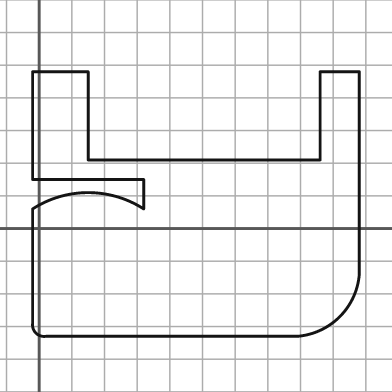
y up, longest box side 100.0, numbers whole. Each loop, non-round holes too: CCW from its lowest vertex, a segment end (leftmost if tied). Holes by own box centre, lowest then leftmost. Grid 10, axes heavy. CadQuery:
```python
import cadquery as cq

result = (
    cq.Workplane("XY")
    .moveTo(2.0, -33.0)
    .lineTo(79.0, -33.0)
    .threePointArc((92.0, -27.0), (98.0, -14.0))
    .lineTo(98.0, 48.0)
    .lineTo(86.0, 48.0)
    .lineTo(86.0, 21.0)
    .lineTo(15.0, 21.0)
    .lineTo(15.0, 48.0)
    .lineTo(-2.0, 48.0)
    .lineTo(-2.0, 15.0)
    .lineTo(32.0, 15.0)
    .lineTo(32.0, 6.0)
    .threePointArc((15.0, 11.0), (-2.0, 6.0))
    .lineTo(-2.0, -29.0)
    .threePointArc((-1.0, -32.0), (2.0, -33.0))
    .close()
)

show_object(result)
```